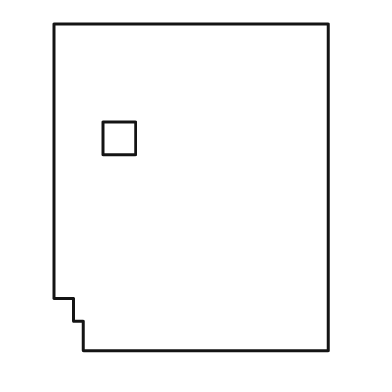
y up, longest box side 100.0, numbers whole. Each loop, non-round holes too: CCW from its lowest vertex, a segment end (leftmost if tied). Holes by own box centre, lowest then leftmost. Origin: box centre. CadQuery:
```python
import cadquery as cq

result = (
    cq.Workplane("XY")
    .moveTo(-33.0, -50.0)
    .lineTo(42.0, -50.0)
    .lineTo(42.0, 50.0)
    .lineTo(-42.0, 50.0)
    .lineTo(-42.0, -34.0)
    .lineTo(-36.0, -34.0)
    .lineTo(-36.0, -41.0)
    .lineTo(-33.0, -41.0)
    .close()
    .moveTo(-27.0, 10.0)
    .lineTo(-17.0, 10.0)
    .lineTo(-17.0, 20.0)
    .lineTo(-27.0, 20.0)
    .close()
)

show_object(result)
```